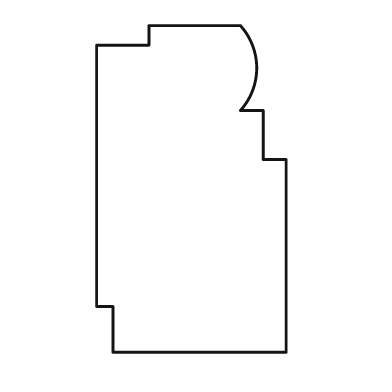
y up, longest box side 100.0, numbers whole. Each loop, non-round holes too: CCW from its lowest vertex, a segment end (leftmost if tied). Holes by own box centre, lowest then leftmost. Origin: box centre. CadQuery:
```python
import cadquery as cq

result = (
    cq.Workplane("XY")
    .moveTo(-24.0, -50.0)
    .lineTo(29.0, -50.0)
    .lineTo(29.0, 9.0)
    .lineTo(22.0, 9.0)
    .lineTo(22.0, 24.0)
    .lineTo(15.0, 24.0)
    .threePointArc((20.0, 37.0), (15.0, 50.0))
    .lineTo(-13.0, 50.0)
    .lineTo(-13.0, 44.0)
    .lineTo(-29.0, 44.0)
    .lineTo(-29.0, -36.0)
    .lineTo(-24.0, -36.0)
    .close()
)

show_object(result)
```